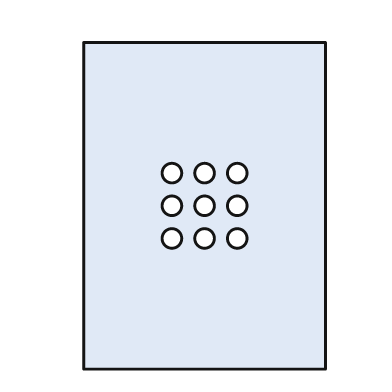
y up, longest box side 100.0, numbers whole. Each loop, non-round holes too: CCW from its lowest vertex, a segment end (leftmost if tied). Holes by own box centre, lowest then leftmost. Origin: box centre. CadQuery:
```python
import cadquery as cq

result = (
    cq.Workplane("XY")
    .moveTo(-37.0, -50.0)
    .lineTo(37.0, -50.0)
    .lineTo(37.0, 50.0)
    .lineTo(-37.0, 50.0)
    .close()
    .moveTo(-10.0, -10.0)
    .circle(3.0)
    .moveTo(0.0, -10.0)
    .circle(3.0)
    .moveTo(10.0, -10.0)
    .circle(3.0)
    .moveTo(-10.0, 0.0)
    .circle(3.0)
    .moveTo(0.0, 0.0)
    .circle(3.0)
    .moveTo(10.0, 0.0)
    .circle(3.0)
    .moveTo(-10.0, 10.0)
    .circle(3.0)
    .moveTo(0.0, 10.0)
    .circle(3.0)
    .moveTo(10.0, 10.0)
    .circle(3.0)
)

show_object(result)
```